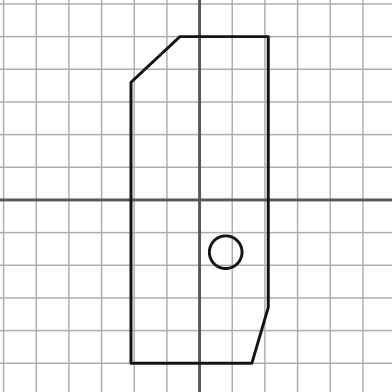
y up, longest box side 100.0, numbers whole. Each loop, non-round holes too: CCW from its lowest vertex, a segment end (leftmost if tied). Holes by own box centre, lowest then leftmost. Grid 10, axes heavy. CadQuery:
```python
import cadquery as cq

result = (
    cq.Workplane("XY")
    .moveTo(-21.0, -50.0)
    .lineTo(16.0, -50.0)
    .lineTo(21.0, -33.0)
    .lineTo(21.0, 50.0)
    .lineTo(-6.0, 50.0)
    .lineTo(-21.0, 36.0)
    .close()
    .moveTo(8.0, -16.0)
    .circle(5.0)
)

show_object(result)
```